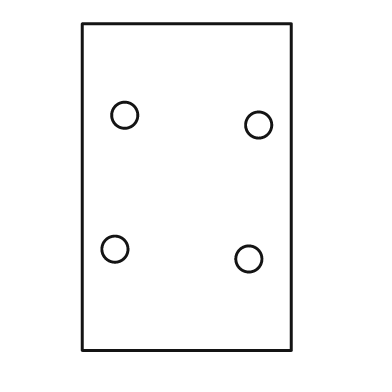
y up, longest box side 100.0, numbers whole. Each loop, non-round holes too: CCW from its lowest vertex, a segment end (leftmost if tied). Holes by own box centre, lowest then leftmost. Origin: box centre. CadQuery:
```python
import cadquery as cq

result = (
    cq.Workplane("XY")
    .moveTo(-32.0, -50.0)
    .lineTo(32.0, -50.0)
    .lineTo(32.0, 50.0)
    .lineTo(-32.0, 50.0)
    .close()
    .moveTo(19.0, -22.0)
    .circle(4.0)
    .moveTo(-22.0, -19.0)
    .circle(4.0)
    .moveTo(22.0, 19.0)
    .circle(4.0)
    .moveTo(-19.0, 22.0)
    .circle(4.0)
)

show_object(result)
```